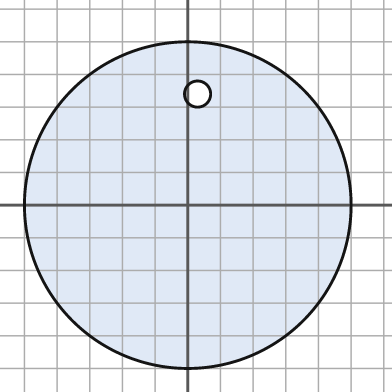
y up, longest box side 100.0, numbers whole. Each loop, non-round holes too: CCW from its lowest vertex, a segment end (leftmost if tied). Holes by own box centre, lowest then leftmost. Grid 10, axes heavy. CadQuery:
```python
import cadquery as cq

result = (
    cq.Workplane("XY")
    .moveTo(0.0, 0.0)
    .circle(50.0)
    .moveTo(3.0, 34.0)
    .circle(4.0)
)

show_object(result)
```